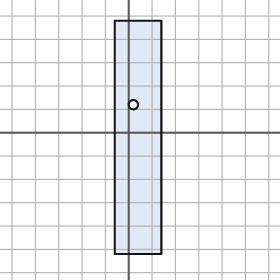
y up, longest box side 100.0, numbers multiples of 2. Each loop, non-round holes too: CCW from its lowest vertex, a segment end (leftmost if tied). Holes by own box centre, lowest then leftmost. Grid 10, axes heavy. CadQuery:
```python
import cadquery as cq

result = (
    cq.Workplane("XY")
    .moveTo(-6.0, -52.0)
    .lineTo(14.0, -52.0)
    .lineTo(14.0, 48.0)
    .lineTo(-6.0, 48.0)
    .close()
    .moveTo(2.0, 12.0)
    .circle(2.0)
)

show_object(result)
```